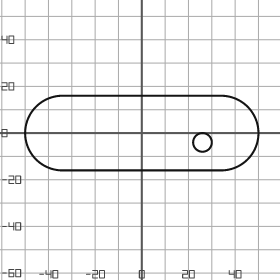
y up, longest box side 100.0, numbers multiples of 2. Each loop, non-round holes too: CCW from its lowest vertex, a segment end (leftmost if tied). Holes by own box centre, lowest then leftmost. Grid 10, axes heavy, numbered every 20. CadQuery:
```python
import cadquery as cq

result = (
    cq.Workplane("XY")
    .moveTo(-34.0, -16.0)
    .lineTo(34.0, -16.0)
    .threePointArc((50.0, 0.0), (34.0, 16.0))
    .lineTo(-34.0, 16.0)
    .threePointArc((-50.0, 0.0), (-34.0, -16.0))
    .close()
    .moveTo(26.0, -4.0)
    .circle(4.0)
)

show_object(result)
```